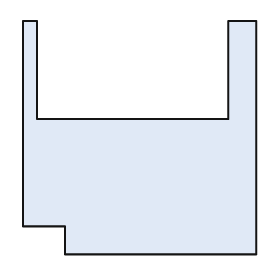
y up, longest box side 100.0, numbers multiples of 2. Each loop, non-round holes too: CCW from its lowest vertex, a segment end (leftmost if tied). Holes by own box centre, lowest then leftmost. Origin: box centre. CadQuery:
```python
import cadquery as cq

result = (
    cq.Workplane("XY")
    .moveTo(-32.0, -50.0)
    .lineTo(50.0, -50.0)
    .lineTo(50.0, 50.0)
    .lineTo(38.0, 50.0)
    .lineTo(38.0, 8.0)
    .lineTo(-44.0, 8.0)
    .lineTo(-44.0, 50.0)
    .lineTo(-50.0, 50.0)
    .lineTo(-50.0, -38.0)
    .lineTo(-32.0, -38.0)
    .close()
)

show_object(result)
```